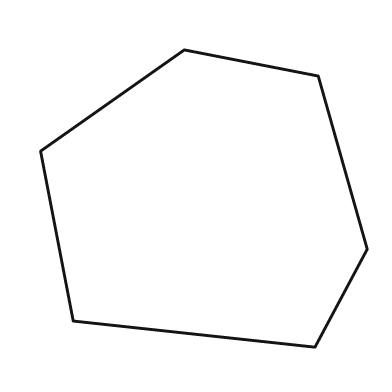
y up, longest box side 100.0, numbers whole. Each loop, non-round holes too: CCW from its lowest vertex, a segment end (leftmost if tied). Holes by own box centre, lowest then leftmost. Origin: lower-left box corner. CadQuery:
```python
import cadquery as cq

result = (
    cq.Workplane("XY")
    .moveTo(84.0, 0.0)
    .lineTo(100.0, 30.0)
    .lineTo(85.0, 83.0)
    .lineTo(44.0, 91.0)
    .lineTo(0.0, 60.0)
    .lineTo(10.0, 8.0)
    .close()
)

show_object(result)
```